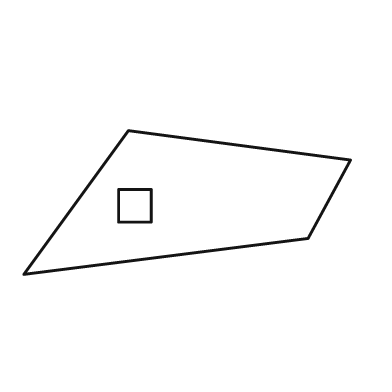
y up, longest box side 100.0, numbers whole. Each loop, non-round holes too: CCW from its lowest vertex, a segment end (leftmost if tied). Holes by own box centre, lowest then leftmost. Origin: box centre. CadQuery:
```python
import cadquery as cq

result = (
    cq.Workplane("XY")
    .moveTo(-50.0, -22.0)
    .lineTo(37.0, -11.0)
    .lineTo(50.0, 13.0)
    .lineTo(-18.0, 22.0)
    .close()
    .moveTo(-21.0, -6.0)
    .lineTo(-11.0, -6.0)
    .lineTo(-11.0, 4.0)
    .lineTo(-21.0, 4.0)
    .close()
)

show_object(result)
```